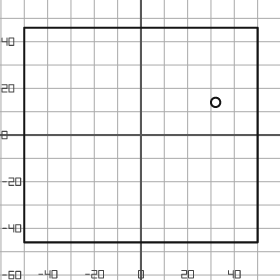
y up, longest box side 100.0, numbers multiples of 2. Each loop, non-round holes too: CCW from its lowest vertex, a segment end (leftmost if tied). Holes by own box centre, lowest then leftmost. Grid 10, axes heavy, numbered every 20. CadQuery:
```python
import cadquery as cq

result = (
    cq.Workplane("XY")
    .moveTo(-50.0, -46.0)
    .lineTo(50.0, -46.0)
    .lineTo(50.0, 46.0)
    .lineTo(-50.0, 46.0)
    .close()
    .moveTo(32.0, 14.0)
    .circle(2.0)
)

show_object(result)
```